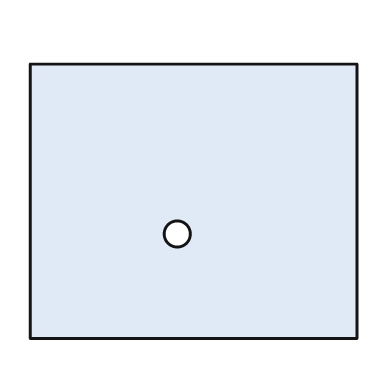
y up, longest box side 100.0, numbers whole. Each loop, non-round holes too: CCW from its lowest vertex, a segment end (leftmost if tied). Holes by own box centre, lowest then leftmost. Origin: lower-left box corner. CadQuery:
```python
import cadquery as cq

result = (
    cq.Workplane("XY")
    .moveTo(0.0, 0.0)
    .lineTo(100.0, 0.0)
    .lineTo(100.0, 84.0)
    .lineTo(0.0, 84.0)
    .close()
    .moveTo(45.0, 32.0)
    .circle(4.0)
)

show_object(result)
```